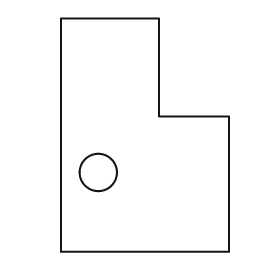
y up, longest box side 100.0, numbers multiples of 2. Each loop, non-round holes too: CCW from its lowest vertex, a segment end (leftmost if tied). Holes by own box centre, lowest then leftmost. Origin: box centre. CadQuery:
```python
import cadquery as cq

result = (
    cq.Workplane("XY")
    .moveTo(-36.0, -50.0)
    .lineTo(36.0, -50.0)
    .lineTo(36.0, 8.0)
    .lineTo(6.0, 8.0)
    .lineTo(6.0, 50.0)
    .lineTo(-36.0, 50.0)
    .close()
    .moveTo(-20.0, -16.0)
    .circle(8.0)
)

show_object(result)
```